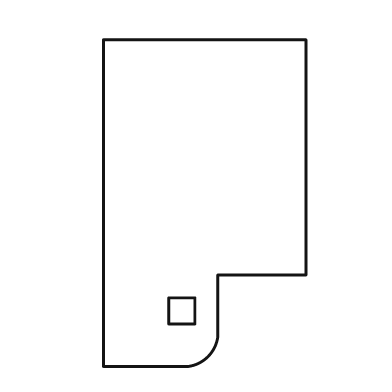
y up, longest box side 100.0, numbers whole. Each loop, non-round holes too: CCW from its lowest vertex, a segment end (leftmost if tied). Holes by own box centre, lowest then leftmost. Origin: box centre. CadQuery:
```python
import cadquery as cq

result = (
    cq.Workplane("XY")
    .moveTo(-31.0, -50.0)
    .lineTo(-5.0, -50.0)
    .threePointArc((1.0, -47.0), (4.0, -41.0))
    .lineTo(4.0, -22.0)
    .lineTo(31.0, -22.0)
    .lineTo(31.0, 50.0)
    .lineTo(-31.0, 50.0)
    .close()
    .moveTo(-11.0, -37.0)
    .lineTo(-3.0, -37.0)
    .lineTo(-3.0, -29.0)
    .lineTo(-11.0, -29.0)
    .close()
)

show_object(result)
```